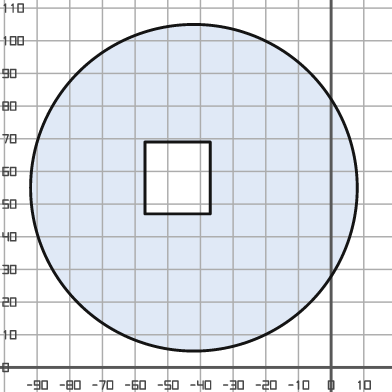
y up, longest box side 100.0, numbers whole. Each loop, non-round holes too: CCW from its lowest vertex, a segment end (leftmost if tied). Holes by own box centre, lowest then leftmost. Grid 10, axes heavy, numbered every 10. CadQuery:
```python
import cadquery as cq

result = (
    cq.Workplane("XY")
    .moveTo(-42.0, 55.0)
    .circle(50.0)
    .moveTo(-57.0, 47.0)
    .lineTo(-37.0, 47.0)
    .lineTo(-37.0, 69.0)
    .lineTo(-57.0, 69.0)
    .close()
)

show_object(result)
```